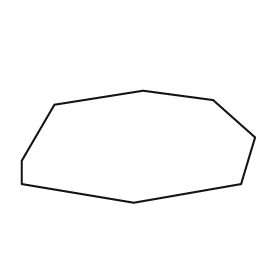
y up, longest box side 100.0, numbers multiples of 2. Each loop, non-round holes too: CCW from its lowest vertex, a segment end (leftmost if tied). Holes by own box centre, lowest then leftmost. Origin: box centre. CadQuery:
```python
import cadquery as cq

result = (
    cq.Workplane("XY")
    .moveTo(-2.0, -24.0)
    .lineTo(44.0, -16.0)
    .lineTo(50.0, 4.0)
    .lineTo(32.0, 20.0)
    .lineTo(2.0, 24.0)
    .lineTo(-36.0, 18.0)
    .lineTo(-50.0, -6.0)
    .lineTo(-50.0, -16.0)
    .close()
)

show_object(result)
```